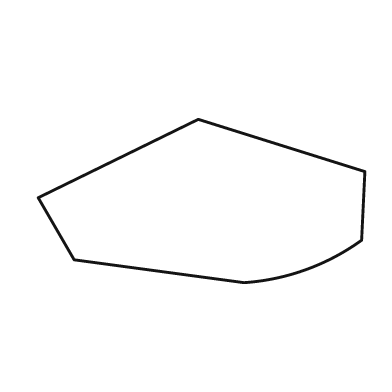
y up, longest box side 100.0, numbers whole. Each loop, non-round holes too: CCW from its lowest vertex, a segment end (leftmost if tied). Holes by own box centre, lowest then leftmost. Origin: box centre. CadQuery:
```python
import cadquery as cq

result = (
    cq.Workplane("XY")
    .moveTo(13.0, -25.0)
    .threePointArc((32.0, -21.0), (49.0, -12.0))
    .lineTo(50.0, 9.0)
    .lineTo(-1.0, 25.0)
    .lineTo(-50.0, 1.0)
    .lineTo(-39.0, -18.0)
    .close()
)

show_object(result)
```